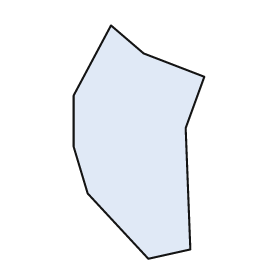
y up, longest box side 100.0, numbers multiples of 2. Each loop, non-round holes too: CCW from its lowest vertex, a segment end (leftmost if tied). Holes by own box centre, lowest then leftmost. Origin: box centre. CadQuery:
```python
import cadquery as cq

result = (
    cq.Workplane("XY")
    .moveTo(4.0, -50.0)
    .lineTo(22.0, -46.0)
    .lineTo(20.0, 6.0)
    .lineTo(28.0, 28.0)
    .lineTo(2.0, 38.0)
    .lineTo(-12.0, 50.0)
    .lineTo(-28.0, 20.0)
    .lineTo(-28.0, -2.0)
    .lineTo(-22.0, -22.0)
    .close()
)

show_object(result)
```